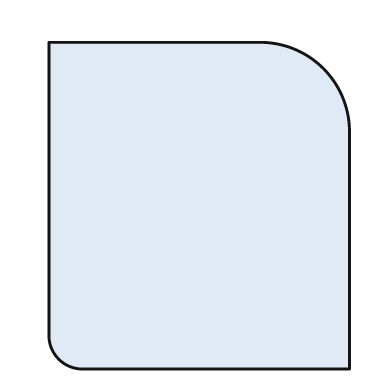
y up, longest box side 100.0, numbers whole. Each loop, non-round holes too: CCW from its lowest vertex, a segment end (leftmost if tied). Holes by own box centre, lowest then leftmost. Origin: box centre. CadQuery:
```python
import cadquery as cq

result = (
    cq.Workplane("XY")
    .moveTo(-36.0, -50.0)
    .lineTo(46.0, -50.0)
    .lineTo(46.0, 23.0)
    .threePointArc((38.0, 42.0), (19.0, 50.0))
    .lineTo(-46.0, 50.0)
    .lineTo(-46.0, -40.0)
    .threePointArc((-43.0, -47.0), (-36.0, -50.0))
    .close()
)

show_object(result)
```